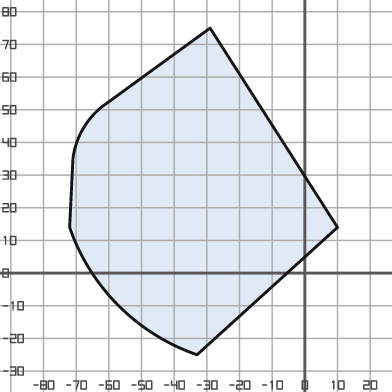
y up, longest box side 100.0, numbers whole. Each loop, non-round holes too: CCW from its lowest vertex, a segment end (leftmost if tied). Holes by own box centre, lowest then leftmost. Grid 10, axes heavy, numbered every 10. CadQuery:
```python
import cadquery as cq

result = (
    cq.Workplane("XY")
    .moveTo(-33.0, -25.0)
    .lineTo(10.0, 14.0)
    .lineTo(-29.0, 75.0)
    .lineTo(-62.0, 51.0)
    .threePointArc((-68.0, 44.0), (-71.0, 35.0))
    .lineTo(-72.0, 14.0)
    .threePointArc((-57.0, -10.0), (-33.0, -25.0))
    .close()
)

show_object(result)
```